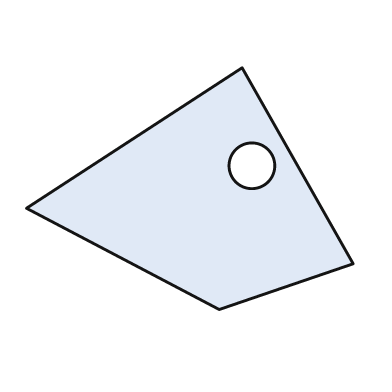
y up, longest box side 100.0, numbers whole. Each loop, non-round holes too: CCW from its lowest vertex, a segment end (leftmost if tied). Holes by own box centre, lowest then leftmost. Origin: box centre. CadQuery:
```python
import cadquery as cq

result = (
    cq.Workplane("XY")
    .moveTo(9.0, -37.0)
    .lineTo(50.0, -23.0)
    .lineTo(16.0, 37.0)
    .lineTo(-50.0, -6.0)
    .close()
    .moveTo(19.0, 7.0)
    .circle(7.0)
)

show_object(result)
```